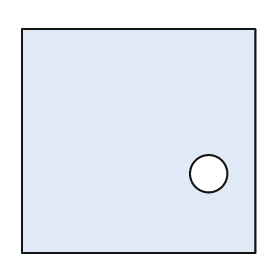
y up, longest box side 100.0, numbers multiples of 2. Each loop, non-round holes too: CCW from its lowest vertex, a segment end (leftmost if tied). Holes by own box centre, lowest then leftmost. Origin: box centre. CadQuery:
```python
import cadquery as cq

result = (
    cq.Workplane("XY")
    .moveTo(-50.0, -48.0)
    .lineTo(50.0, -48.0)
    .lineTo(50.0, 48.0)
    .lineTo(-50.0, 48.0)
    .close()
    .moveTo(30.0, -14.0)
    .circle(8.0)
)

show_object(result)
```